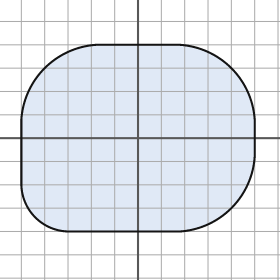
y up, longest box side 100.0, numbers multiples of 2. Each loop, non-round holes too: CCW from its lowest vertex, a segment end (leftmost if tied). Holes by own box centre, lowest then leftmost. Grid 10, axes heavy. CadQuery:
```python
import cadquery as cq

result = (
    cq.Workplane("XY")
    .moveTo(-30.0, -40.0)
    .lineTo(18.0, -40.0)
    .threePointArc((40.0, -30.0), (50.0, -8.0))
    .lineTo(50.0, 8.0)
    .threePointArc((40.0, 30.0), (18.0, 40.0))
    .lineTo(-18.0, 40.0)
    .threePointArc((-40.0, 30.0), (-50.0, 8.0))
    .lineTo(-50.0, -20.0)
    .threePointArc((-44.0, -34.0), (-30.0, -40.0))
    .close()
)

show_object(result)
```